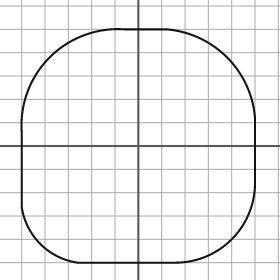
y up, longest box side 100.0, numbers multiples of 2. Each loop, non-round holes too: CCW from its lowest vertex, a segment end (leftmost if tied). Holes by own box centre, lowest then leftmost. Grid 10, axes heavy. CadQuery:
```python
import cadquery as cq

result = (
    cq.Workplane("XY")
    .moveTo(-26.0, -50.0)
    .lineTo(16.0, -50.0)
    .threePointArc((40.0, -40.0), (50.0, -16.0))
    .lineTo(50.0, 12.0)
    .threePointArc((38.0, 38.0), (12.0, 50.0))
    .lineTo(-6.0, 50.0)
    .threePointArc((-38.0, 38.0), (-50.0, 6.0))
    .lineTo(-50.0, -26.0)
    .threePointArc((-42.0, -42.0), (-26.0, -50.0))
    .close()
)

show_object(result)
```